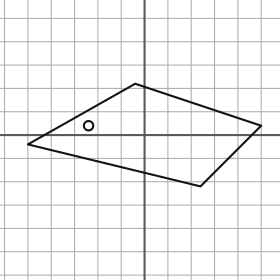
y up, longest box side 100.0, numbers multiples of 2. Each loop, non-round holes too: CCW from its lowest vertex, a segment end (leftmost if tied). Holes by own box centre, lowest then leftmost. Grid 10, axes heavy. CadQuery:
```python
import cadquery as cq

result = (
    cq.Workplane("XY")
    .moveTo(24.0, -22.0)
    .lineTo(50.0, 4.0)
    .lineTo(-4.0, 22.0)
    .lineTo(-50.0, -4.0)
    .close()
    .moveTo(-24.0, 4.0)
    .circle(2.0)
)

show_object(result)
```